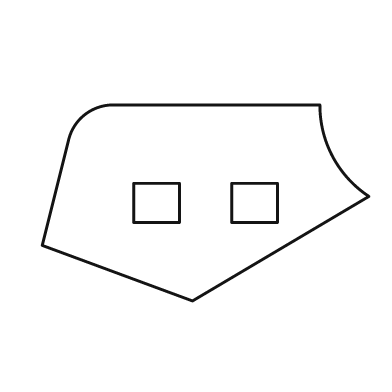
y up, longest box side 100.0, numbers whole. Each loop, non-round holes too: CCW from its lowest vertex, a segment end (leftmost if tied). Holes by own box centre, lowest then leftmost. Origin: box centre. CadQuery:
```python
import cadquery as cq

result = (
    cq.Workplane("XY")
    .moveTo(-4.0, -30.0)
    .lineTo(50.0, 2.0)
    .threePointArc((39.0, 14.0), (35.0, 30.0))
    .lineTo(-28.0, 30.0)
    .threePointArc((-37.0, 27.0), (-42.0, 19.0))
    .lineTo(-50.0, -13.0)
    .close()
    .moveTo(-22.0, -6.0)
    .lineTo(-8.0, -6.0)
    .lineTo(-8.0, 6.0)
    .lineTo(-22.0, 6.0)
    .close()
    .moveTo(8.0, -6.0)
    .lineTo(22.0, -6.0)
    .lineTo(22.0, 6.0)
    .lineTo(8.0, 6.0)
    .close()
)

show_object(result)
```